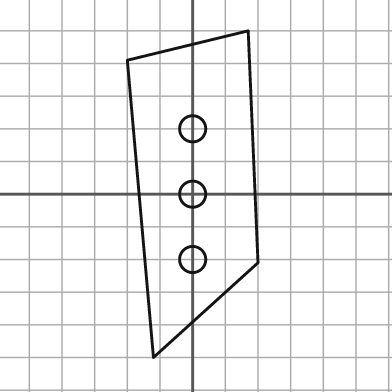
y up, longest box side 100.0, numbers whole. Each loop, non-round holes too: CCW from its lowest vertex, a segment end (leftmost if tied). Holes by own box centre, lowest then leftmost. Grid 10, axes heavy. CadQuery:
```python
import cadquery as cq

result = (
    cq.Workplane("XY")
    .moveTo(-12.0, -50.0)
    .lineTo(20.0, -21.0)
    .lineTo(17.0, 50.0)
    .lineTo(-20.0, 41.0)
    .close()
    .moveTo(0.0, -20.0)
    .circle(4.0)
    .moveTo(0.0, 0.0)
    .circle(4.0)
    .moveTo(0.0, 20.0)
    .circle(4.0)
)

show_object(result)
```